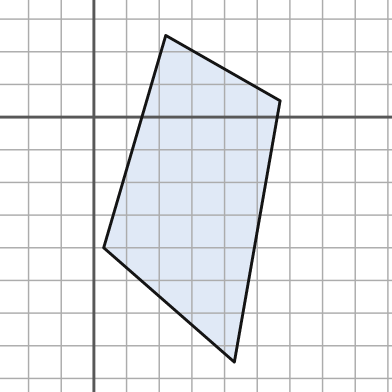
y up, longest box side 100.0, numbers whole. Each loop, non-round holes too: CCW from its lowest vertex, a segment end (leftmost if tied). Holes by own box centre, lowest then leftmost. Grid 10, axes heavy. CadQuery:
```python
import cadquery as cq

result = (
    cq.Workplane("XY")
    .moveTo(43.0, -75.0)
    .lineTo(57.0, 5.0)
    .lineTo(22.0, 25.0)
    .lineTo(3.0, -40.0)
    .close()
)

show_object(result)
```